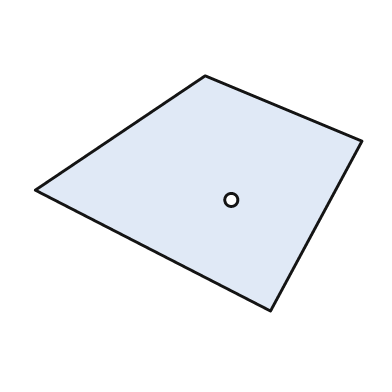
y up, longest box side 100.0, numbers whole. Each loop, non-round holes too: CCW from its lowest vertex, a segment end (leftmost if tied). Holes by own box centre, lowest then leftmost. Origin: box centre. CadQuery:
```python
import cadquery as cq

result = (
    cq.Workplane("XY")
    .moveTo(22.0, -36.0)
    .lineTo(50.0, 16.0)
    .lineTo(2.0, 36.0)
    .lineTo(-50.0, 1.0)
    .close()
    .moveTo(10.0, -2.0)
    .circle(2.0)
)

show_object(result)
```